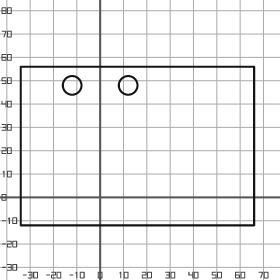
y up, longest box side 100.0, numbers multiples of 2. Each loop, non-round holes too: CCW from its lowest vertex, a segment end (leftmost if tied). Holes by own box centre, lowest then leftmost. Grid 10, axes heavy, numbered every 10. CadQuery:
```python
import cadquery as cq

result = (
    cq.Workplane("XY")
    .moveTo(-34.0, -12.0)
    .lineTo(66.0, -12.0)
    .lineTo(66.0, 56.0)
    .lineTo(-34.0, 56.0)
    .close()
    .moveTo(-12.0, 48.0)
    .circle(4.0)
    .moveTo(12.0, 48.0)
    .circle(4.0)
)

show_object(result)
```